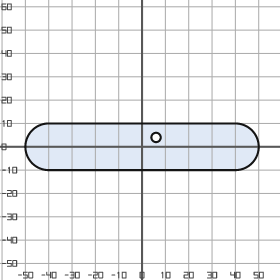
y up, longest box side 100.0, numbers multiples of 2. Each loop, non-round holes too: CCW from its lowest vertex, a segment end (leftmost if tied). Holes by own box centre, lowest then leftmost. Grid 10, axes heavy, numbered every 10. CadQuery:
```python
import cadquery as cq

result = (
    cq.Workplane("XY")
    .moveTo(-40.0, -10.0)
    .lineTo(40.0, -10.0)
    .threePointArc((50.0, 0.0), (40.0, 10.0))
    .lineTo(-40.0, 10.0)
    .threePointArc((-50.0, 0.0), (-40.0, -10.0))
    .close()
    .moveTo(6.0, 4.0)
    .circle(2.0)
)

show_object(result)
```